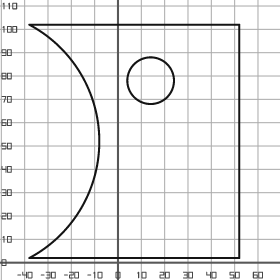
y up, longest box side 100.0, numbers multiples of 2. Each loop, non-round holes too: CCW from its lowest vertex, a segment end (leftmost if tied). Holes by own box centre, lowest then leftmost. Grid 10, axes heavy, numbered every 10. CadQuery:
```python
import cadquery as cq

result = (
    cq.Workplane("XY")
    .moveTo(-38.0, 2.0)
    .lineTo(52.0, 2.0)
    .lineTo(52.0, 102.0)
    .lineTo(-38.0, 102.0)
    .threePointArc((-8.0, 52.0), (-38.0, 2.0))
    .close()
    .moveTo(14.0, 78.0)
    .circle(10.0)
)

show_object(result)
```